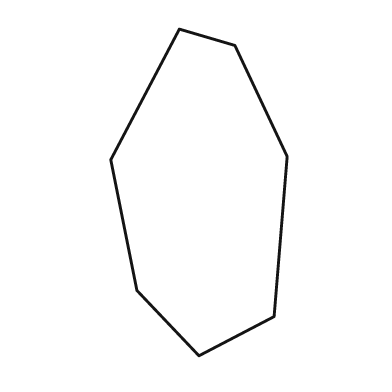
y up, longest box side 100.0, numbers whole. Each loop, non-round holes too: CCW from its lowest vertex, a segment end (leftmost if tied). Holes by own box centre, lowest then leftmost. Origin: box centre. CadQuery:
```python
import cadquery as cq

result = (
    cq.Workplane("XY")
    .moveTo(0.0, -50.0)
    .lineTo(23.0, -38.0)
    .lineTo(27.0, 11.0)
    .lineTo(11.0, 45.0)
    .lineTo(-6.0, 50.0)
    .lineTo(-27.0, 10.0)
    .lineTo(-19.0, -30.0)
    .close()
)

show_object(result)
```